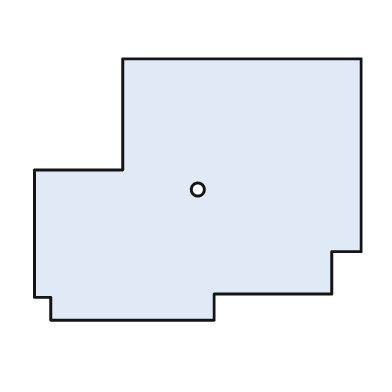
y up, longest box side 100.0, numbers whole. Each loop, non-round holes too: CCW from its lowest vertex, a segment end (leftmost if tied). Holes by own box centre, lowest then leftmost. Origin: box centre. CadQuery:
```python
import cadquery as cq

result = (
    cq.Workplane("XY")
    .moveTo(-45.0, -40.0)
    .lineTo(5.0, -40.0)
    .lineTo(5.0, -32.0)
    .lineTo(41.0, -32.0)
    .lineTo(41.0, -19.0)
    .lineTo(50.0, -19.0)
    .lineTo(50.0, 40.0)
    .lineTo(-23.0, 40.0)
    .lineTo(-23.0, 6.0)
    .lineTo(-50.0, 6.0)
    .lineTo(-50.0, -33.0)
    .lineTo(-45.0, -33.0)
    .close()
    .moveTo(0.0, 0.0)
    .circle(2.0)
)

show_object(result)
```